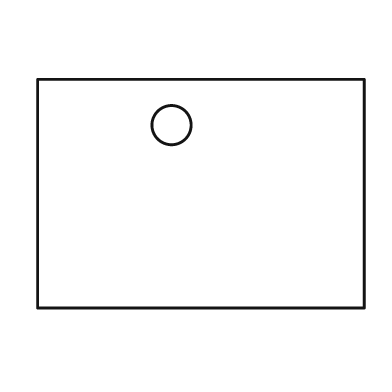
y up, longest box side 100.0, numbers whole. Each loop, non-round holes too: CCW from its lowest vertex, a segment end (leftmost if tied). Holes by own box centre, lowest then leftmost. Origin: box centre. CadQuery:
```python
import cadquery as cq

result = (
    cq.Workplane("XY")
    .moveTo(-50.0, -35.0)
    .lineTo(50.0, -35.0)
    .lineTo(50.0, 35.0)
    .lineTo(-50.0, 35.0)
    .close()
    .moveTo(-9.0, 21.0)
    .circle(6.0)
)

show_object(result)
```